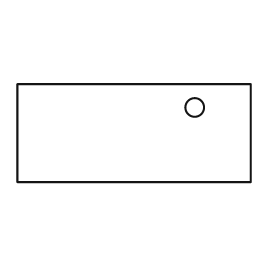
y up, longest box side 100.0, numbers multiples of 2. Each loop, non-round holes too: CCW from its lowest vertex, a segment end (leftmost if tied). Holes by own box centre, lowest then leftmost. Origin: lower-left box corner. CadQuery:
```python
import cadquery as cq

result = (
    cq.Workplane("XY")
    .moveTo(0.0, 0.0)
    .lineTo(100.0, 0.0)
    .lineTo(100.0, 42.0)
    .lineTo(0.0, 42.0)
    .close()
    .moveTo(76.0, 32.0)
    .circle(4.0)
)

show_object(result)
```